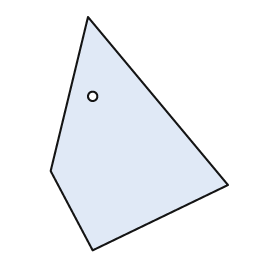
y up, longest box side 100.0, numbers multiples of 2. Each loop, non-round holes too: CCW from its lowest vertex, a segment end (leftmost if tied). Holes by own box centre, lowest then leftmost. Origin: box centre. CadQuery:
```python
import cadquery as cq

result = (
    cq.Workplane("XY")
    .moveTo(-20.0, -50.0)
    .lineTo(38.0, -22.0)
    .lineTo(-22.0, 50.0)
    .lineTo(-38.0, -16.0)
    .close()
    .moveTo(-20.0, 16.0)
    .circle(2.0)
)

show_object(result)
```